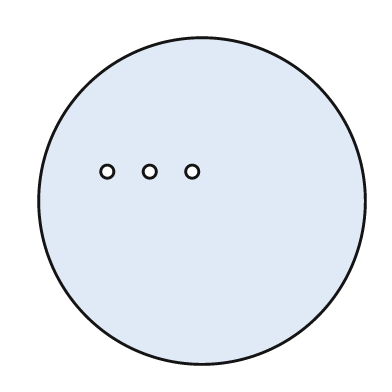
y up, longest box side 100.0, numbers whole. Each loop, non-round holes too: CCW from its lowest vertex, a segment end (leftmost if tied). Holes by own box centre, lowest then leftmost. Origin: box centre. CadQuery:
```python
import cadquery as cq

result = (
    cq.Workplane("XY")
    .moveTo(0.0, 0.0)
    .circle(50.0)
    .moveTo(-29.0, 9.0)
    .circle(2.0)
    .moveTo(-16.0, 9.0)
    .circle(2.0)
    .moveTo(-3.0, 9.0)
    .circle(2.0)
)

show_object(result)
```